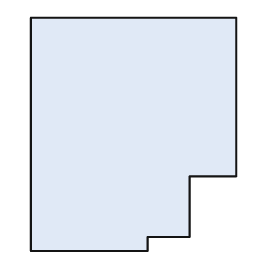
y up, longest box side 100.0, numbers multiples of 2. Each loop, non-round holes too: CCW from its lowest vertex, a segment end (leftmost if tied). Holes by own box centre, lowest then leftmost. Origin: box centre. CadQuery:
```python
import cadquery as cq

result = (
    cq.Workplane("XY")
    .moveTo(-44.0, -50.0)
    .lineTo(6.0, -50.0)
    .lineTo(6.0, -44.0)
    .lineTo(24.0, -44.0)
    .lineTo(24.0, -18.0)
    .lineTo(44.0, -18.0)
    .lineTo(44.0, 50.0)
    .lineTo(-44.0, 50.0)
    .close()
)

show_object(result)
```